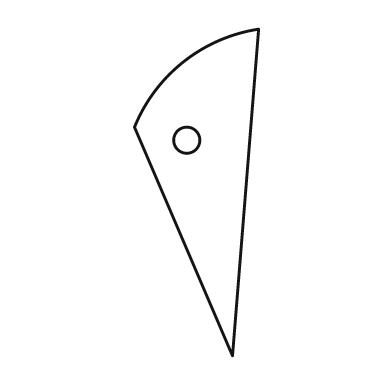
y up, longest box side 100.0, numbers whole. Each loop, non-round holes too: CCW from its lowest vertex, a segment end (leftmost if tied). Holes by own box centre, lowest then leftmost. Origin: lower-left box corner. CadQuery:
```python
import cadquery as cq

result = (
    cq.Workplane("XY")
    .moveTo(30.0, 0.0)
    .lineTo(38.0, 100.0)
    .threePointArc((15.0, 90.0), (0.0, 70.0))
    .close()
    .moveTo(16.0, 66.0)
    .circle(4.0)
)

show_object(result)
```